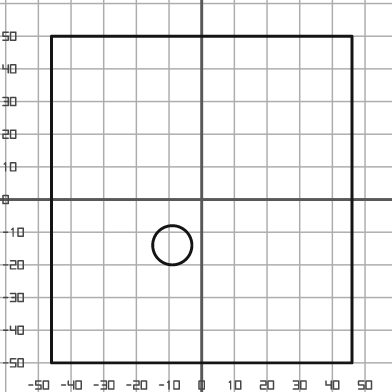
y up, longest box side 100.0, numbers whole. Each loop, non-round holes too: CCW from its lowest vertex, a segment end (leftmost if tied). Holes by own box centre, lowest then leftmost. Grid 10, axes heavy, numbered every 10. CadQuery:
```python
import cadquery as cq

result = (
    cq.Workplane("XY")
    .moveTo(-46.0, -50.0)
    .lineTo(46.0, -50.0)
    .lineTo(46.0, 50.0)
    .lineTo(-46.0, 50.0)
    .close()
    .moveTo(-9.0, -14.0)
    .circle(6.0)
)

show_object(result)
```